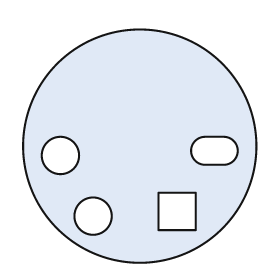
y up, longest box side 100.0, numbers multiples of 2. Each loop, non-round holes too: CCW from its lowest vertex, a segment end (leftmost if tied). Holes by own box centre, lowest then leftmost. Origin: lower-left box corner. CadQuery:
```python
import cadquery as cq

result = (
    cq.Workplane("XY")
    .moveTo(50.0, 50.0)
    .circle(50.0)
    .moveTo(30.0, 20.0)
    .circle(8.0)
    .moveTo(58.0, 14.0)
    .lineTo(74.0, 14.0)
    .lineTo(74.0, 30.0)
    .lineTo(58.0, 30.0)
    .close()
    .moveTo(16.0, 46.0)
    .circle(8.0)
    .moveTo(78.0, 42.0)
    .lineTo(86.0, 42.0)
    .threePointArc((92.0, 48.0), (86.0, 54.0))
    .lineTo(78.0, 54.0)
    .threePointArc((72.0, 48.0), (78.0, 42.0))
    .close()
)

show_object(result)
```